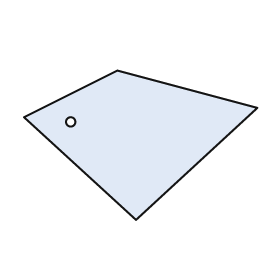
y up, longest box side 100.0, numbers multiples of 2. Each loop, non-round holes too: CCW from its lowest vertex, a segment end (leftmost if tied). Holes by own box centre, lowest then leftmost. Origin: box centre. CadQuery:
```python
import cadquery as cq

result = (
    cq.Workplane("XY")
    .moveTo(-2.0, -32.0)
    .lineTo(50.0, 16.0)
    .lineTo(-10.0, 32.0)
    .lineTo(-50.0, 12.0)
    .close()
    .moveTo(-30.0, 10.0)
    .circle(2.0)
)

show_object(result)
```